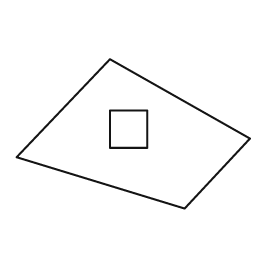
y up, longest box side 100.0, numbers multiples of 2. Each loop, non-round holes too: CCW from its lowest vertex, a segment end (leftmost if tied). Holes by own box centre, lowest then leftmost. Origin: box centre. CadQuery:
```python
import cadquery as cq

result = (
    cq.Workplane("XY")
    .moveTo(22.0, -32.0)
    .lineTo(50.0, -2.0)
    .lineTo(-10.0, 32.0)
    .lineTo(-50.0, -10.0)
    .close()
    .moveTo(-10.0, -6.0)
    .lineTo(6.0, -6.0)
    .lineTo(6.0, 10.0)
    .lineTo(-10.0, 10.0)
    .close()
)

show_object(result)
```